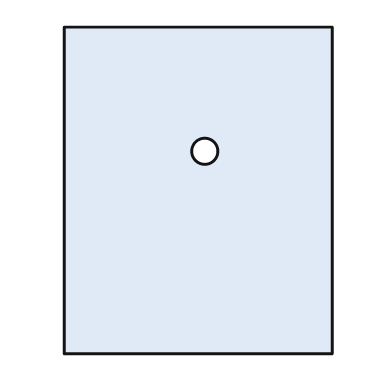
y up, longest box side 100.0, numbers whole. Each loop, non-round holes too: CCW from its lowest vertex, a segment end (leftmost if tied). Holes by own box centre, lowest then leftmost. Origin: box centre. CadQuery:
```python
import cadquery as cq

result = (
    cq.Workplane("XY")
    .moveTo(-41.0, -50.0)
    .lineTo(41.0, -50.0)
    .lineTo(41.0, 50.0)
    .lineTo(-41.0, 50.0)
    .close()
    .moveTo(2.0, 12.0)
    .circle(4.0)
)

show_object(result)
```